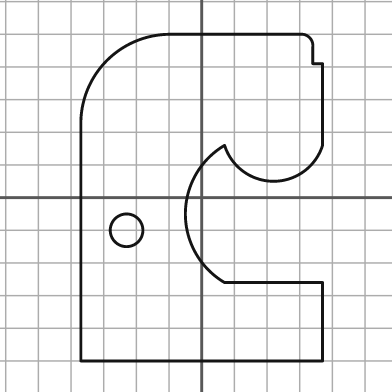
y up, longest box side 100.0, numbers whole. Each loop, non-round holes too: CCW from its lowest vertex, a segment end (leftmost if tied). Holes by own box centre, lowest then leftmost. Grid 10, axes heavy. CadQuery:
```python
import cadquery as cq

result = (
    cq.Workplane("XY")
    .moveTo(-37.0, -50.0)
    .lineTo(37.0, -50.0)
    .lineTo(37.0, -26.0)
    .lineTo(7.0, -26.0)
    .threePointArc((-5.0, -5.0), (7.0, 16.0))
    .threePointArc((22.0, 5.0), (37.0, 16.0))
    .lineTo(37.0, 41.0)
    .lineTo(34.0, 41.0)
    .lineTo(34.0, 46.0)
    .threePointArc((33.0, 49.0), (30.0, 50.0))
    .lineTo(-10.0, 50.0)
    .threePointArc((-29.0, 42.0), (-37.0, 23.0))
    .close()
    .moveTo(-23.0, -10.0)
    .circle(5.0)
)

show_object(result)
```